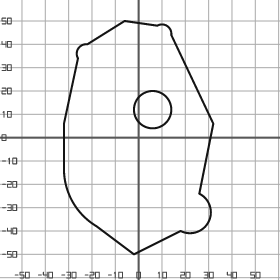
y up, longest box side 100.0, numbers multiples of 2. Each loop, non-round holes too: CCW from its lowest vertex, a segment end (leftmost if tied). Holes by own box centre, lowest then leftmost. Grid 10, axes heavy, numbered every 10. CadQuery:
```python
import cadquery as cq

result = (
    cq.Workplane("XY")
    .moveTo(-2.0, -50.0)
    .lineTo(18.0, -40.0)
    .threePointArc((30.0, -36.0), (26.0, -24.0))
    .lineTo(32.0, 6.0)
    .lineTo(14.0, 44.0)
    .threePointArc((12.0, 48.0), (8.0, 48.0))
    .lineTo(-6.0, 50.0)
    .lineTo(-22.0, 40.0)
    .threePointArc((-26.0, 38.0), (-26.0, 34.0))
    .lineTo(-32.0, 6.0)
    .lineTo(-32.0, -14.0)
    .threePointArc((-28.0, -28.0), (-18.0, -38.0))
    .close()
    .moveTo(6.0, 12.0)
    .circle(8.0)
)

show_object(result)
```